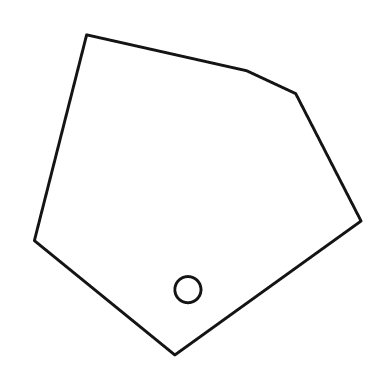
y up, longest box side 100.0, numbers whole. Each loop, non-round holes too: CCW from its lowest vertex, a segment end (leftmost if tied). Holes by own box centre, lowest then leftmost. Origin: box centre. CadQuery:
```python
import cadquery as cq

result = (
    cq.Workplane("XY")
    .moveTo(-7.0, -49.0)
    .lineTo(50.0, -8.0)
    .lineTo(30.0, 31.0)
    .lineTo(15.0, 38.0)
    .lineTo(-34.0, 49.0)
    .lineTo(-50.0, -14.0)
    .close()
    .moveTo(-3.0, -29.0)
    .circle(4.0)
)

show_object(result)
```